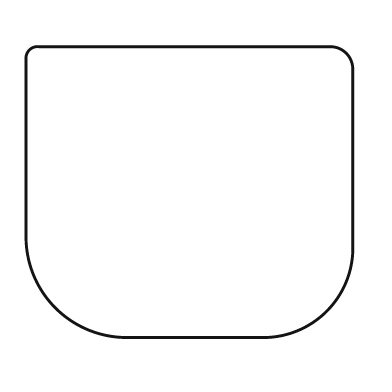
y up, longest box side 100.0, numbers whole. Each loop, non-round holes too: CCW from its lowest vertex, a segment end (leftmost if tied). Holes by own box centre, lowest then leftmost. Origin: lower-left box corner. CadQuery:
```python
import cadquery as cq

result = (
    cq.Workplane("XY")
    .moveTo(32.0, 0.0)
    .lineTo(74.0, 0.0)
    .threePointArc((92.0, 8.0), (100.0, 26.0))
    .lineTo(100.0, 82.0)
    .threePointArc((98.0, 87.0), (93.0, 89.0))
    .lineTo(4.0, 89.0)
    .threePointArc((1.0, 88.0), (0.0, 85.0))
    .lineTo(0.0, 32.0)
    .threePointArc((9.0, 9.0), (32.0, 0.0))
    .close()
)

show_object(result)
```